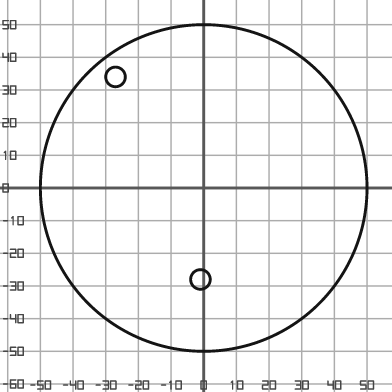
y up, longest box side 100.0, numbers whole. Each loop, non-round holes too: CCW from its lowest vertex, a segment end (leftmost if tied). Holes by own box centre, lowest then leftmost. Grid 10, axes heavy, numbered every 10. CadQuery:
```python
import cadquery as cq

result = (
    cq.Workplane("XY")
    .moveTo(0.0, 0.0)
    .circle(50.0)
    .moveTo(-1.0, -28.0)
    .circle(3.0)
    .moveTo(-27.0, 34.0)
    .circle(3.0)
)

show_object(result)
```